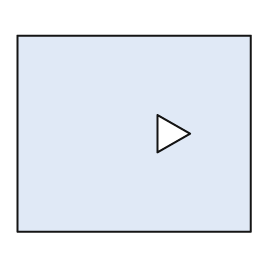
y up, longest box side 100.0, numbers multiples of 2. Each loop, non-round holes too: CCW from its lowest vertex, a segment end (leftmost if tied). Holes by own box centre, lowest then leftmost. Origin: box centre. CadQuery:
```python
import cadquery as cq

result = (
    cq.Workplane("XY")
    .moveTo(-50.0, -42.0)
    .lineTo(50.0, -42.0)
    .lineTo(50.0, 42.0)
    .lineTo(-50.0, 42.0)
    .close()
    .moveTo(10.0, -8.0)
    .lineTo(24.0, 0.0)
    .lineTo(10.0, 8.0)
    .close()
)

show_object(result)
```